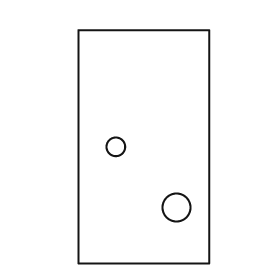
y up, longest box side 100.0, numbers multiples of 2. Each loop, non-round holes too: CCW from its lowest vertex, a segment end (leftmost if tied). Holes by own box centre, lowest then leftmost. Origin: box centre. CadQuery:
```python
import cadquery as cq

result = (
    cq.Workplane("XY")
    .moveTo(-28.0, -50.0)
    .lineTo(28.0, -50.0)
    .lineTo(28.0, 50.0)
    .lineTo(-28.0, 50.0)
    .close()
    .moveTo(14.0, -26.0)
    .circle(6.0)
    .moveTo(-12.0, 0.0)
    .circle(4.0)
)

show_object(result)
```